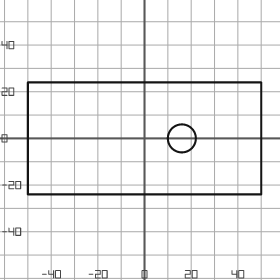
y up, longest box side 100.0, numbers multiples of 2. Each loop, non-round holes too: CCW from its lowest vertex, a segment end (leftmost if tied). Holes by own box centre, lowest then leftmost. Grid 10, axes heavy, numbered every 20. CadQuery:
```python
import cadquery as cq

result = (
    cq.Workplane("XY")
    .moveTo(-50.0, -24.0)
    .lineTo(50.0, -24.0)
    .lineTo(50.0, 24.0)
    .lineTo(-50.0, 24.0)
    .close()
    .moveTo(16.0, 0.0)
    .circle(6.0)
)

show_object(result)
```